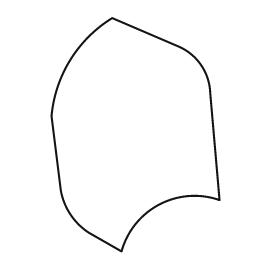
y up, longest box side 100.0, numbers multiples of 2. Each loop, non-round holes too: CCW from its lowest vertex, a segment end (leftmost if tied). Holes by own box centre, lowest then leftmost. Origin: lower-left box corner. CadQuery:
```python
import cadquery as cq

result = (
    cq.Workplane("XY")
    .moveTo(30.0, 0.0)
    .threePointArc((46.0, 20.0), (72.0, 22.0))
    .lineTo(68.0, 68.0)
    .threePointArc((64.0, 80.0), (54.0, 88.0))
    .lineTo(26.0, 100.0)
    .threePointArc((8.0, 82.0), (0.0, 58.0))
    .lineTo(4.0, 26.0)
    .threePointArc((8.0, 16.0), (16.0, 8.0))
    .close()
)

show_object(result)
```